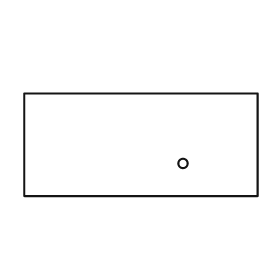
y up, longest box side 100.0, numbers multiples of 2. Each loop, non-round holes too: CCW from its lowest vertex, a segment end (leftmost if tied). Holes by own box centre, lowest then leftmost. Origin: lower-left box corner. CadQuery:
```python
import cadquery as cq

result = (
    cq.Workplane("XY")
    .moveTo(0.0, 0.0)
    .lineTo(100.0, 0.0)
    .lineTo(100.0, 44.0)
    .lineTo(0.0, 44.0)
    .close()
    .moveTo(68.0, 14.0)
    .circle(2.0)
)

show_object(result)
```